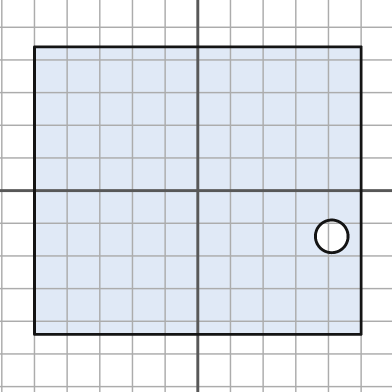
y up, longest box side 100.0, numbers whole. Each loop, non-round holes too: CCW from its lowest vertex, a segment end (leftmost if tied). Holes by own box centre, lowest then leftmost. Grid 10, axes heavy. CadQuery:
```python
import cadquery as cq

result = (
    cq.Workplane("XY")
    .moveTo(-50.0, -44.0)
    .lineTo(50.0, -44.0)
    .lineTo(50.0, 44.0)
    .lineTo(-50.0, 44.0)
    .close()
    .moveTo(41.0, -14.0)
    .circle(5.0)
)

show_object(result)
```